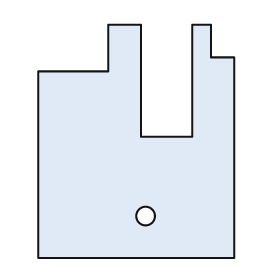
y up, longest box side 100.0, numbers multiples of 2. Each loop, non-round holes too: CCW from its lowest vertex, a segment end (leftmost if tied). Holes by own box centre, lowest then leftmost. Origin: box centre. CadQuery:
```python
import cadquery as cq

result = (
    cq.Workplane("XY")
    .moveTo(-42.0, -50.0)
    .lineTo(42.0, -50.0)
    .lineTo(42.0, 36.0)
    .lineTo(32.0, 36.0)
    .lineTo(32.0, 50.0)
    .lineTo(24.0, 50.0)
    .lineTo(24.0, 2.0)
    .lineTo(2.0, 2.0)
    .lineTo(2.0, 50.0)
    .lineTo(-12.0, 50.0)
    .lineTo(-12.0, 30.0)
    .lineTo(-42.0, 30.0)
    .close()
    .moveTo(4.0, -32.0)
    .circle(4.0)
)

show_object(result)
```